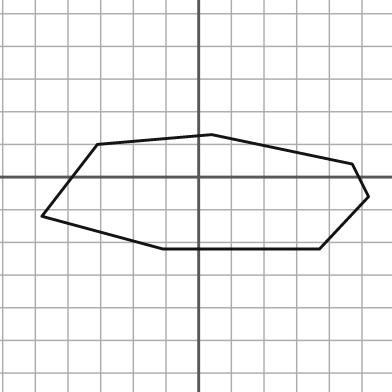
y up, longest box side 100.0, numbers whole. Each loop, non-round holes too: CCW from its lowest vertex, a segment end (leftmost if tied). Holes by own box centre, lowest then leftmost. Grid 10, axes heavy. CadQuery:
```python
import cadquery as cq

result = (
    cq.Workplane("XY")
    .moveTo(-11.0, -22.0)
    .lineTo(37.0, -22.0)
    .lineTo(52.0, -6.0)
    .lineTo(47.0, 4.0)
    .lineTo(4.0, 13.0)
    .lineTo(-31.0, 10.0)
    .lineTo(-48.0, -12.0)
    .close()
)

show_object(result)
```